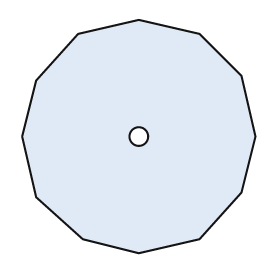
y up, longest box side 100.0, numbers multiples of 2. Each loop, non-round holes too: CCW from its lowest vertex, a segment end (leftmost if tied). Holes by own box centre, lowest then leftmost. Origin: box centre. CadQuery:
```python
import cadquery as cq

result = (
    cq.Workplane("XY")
    .moveTo(0.0, -50.0)
    .lineTo(26.0, -44.0)
    .lineTo(44.0, -24.0)
    .lineTo(50.0, 0.0)
    .lineTo(44.0, 26.0)
    .lineTo(26.0, 44.0)
    .lineTo(0.0, 50.0)
    .lineTo(-26.0, 44.0)
    .lineTo(-44.0, 24.0)
    .lineTo(-50.0, 0.0)
    .lineTo(-44.0, -26.0)
    .lineTo(-24.0, -44.0)
    .close()
    .moveTo(0.0, 0.0)
    .circle(4.0)
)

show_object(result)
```